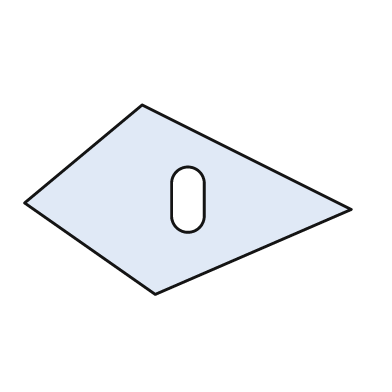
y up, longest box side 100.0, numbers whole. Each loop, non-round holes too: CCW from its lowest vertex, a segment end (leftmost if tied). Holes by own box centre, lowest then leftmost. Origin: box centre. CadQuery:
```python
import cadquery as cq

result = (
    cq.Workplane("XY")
    .moveTo(-10.0, -29.0)
    .lineTo(50.0, -3.0)
    .lineTo(-14.0, 29.0)
    .lineTo(-50.0, -1.0)
    .close()
    .moveTo(-5.0, -5.0)
    .threePointArc((0.0, -10.0), (5.0, -5.0))
    .lineTo(5.0, 5.0)
    .threePointArc((0.0, 10.0), (-5.0, 5.0))
    .close()
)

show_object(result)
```